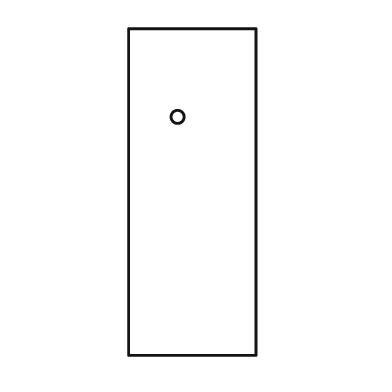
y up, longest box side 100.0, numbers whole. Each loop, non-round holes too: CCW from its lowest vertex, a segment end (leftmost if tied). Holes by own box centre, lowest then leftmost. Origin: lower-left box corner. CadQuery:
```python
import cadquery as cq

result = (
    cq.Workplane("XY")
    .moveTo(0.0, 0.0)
    .lineTo(39.0, 0.0)
    .lineTo(39.0, 100.0)
    .lineTo(0.0, 100.0)
    .close()
    .moveTo(15.0, 73.0)
    .circle(2.0)
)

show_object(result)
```